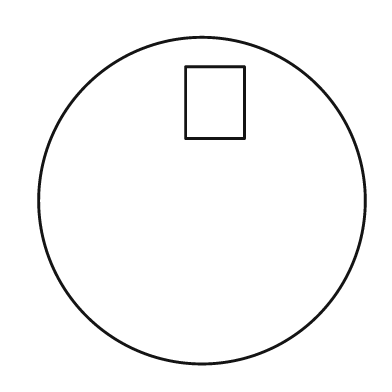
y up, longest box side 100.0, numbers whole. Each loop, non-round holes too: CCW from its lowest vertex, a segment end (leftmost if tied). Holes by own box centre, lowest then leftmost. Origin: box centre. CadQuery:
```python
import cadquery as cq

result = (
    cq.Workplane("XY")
    .moveTo(0.0, 0.0)
    .circle(50.0)
    .moveTo(-5.0, 19.0)
    .lineTo(13.0, 19.0)
    .lineTo(13.0, 41.0)
    .lineTo(-5.0, 41.0)
    .close()
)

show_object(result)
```